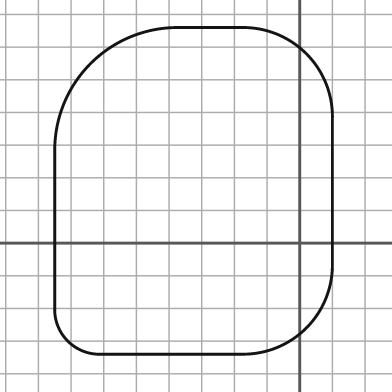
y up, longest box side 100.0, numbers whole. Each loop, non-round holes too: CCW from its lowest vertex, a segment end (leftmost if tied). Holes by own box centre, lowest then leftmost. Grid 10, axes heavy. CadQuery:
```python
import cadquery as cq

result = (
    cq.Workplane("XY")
    .moveTo(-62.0, -34.0)
    .lineTo(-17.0, -34.0)
    .threePointArc((2.0, -26.0), (10.0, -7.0))
    .lineTo(10.0, 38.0)
    .threePointArc((2.0, 58.0), (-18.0, 66.0))
    .lineTo(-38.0, 66.0)
    .threePointArc((-64.0, 55.0), (-75.0, 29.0))
    .lineTo(-75.0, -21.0)
    .threePointArc((-71.0, -30.0), (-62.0, -34.0))
    .close()
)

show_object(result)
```